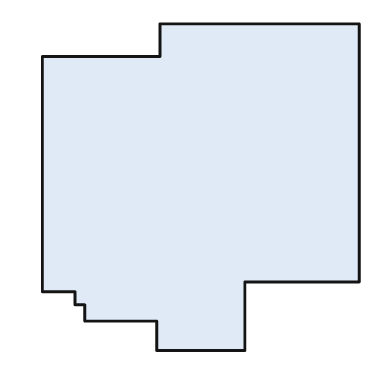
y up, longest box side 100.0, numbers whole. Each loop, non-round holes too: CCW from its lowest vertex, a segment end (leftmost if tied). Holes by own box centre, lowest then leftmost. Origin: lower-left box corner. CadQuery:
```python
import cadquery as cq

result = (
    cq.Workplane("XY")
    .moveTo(35.0, 0.0)
    .lineTo(62.0, 0.0)
    .lineTo(62.0, 21.0)
    .lineTo(97.0, 21.0)
    .lineTo(97.0, 100.0)
    .lineTo(36.0, 100.0)
    .lineTo(36.0, 90.0)
    .lineTo(0.0, 90.0)
    .lineTo(0.0, 18.0)
    .lineTo(10.0, 18.0)
    .lineTo(10.0, 14.0)
    .lineTo(13.0, 14.0)
    .lineTo(13.0, 9.0)
    .lineTo(35.0, 9.0)
    .close()
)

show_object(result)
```